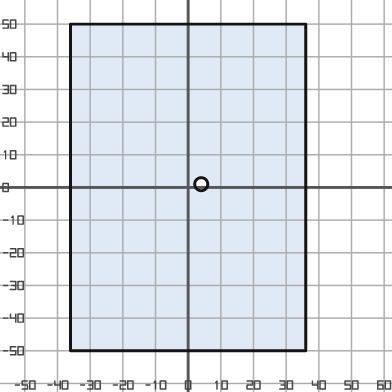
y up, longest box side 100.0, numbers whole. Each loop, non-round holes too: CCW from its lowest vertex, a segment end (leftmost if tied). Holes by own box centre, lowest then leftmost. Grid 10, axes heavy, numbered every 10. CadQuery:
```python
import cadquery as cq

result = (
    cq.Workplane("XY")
    .moveTo(-36.0, -50.0)
    .lineTo(36.0, -50.0)
    .lineTo(36.0, 50.0)
    .lineTo(-36.0, 50.0)
    .close()
    .moveTo(4.0, 1.0)
    .circle(2.0)
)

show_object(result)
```